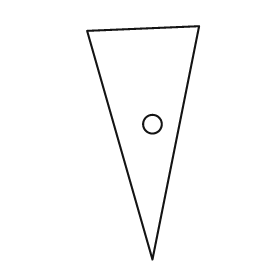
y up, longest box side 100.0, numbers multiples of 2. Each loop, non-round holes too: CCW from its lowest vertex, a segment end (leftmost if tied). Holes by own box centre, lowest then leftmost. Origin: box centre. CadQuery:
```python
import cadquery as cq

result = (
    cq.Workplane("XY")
    .moveTo(4.0, -50.0)
    .lineTo(24.0, 50.0)
    .lineTo(-24.0, 48.0)
    .close()
    .moveTo(4.0, 8.0)
    .circle(4.0)
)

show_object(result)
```